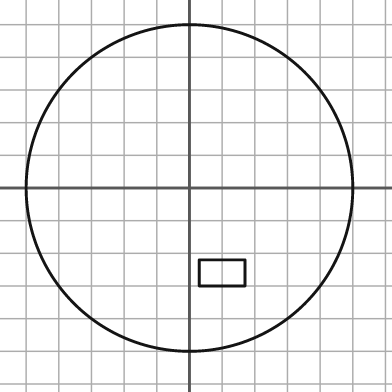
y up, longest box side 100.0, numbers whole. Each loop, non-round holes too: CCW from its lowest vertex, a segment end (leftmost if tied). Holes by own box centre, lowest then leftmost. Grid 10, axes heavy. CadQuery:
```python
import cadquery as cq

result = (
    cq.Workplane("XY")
    .moveTo(0.0, 0.0)
    .circle(50.0)
    .moveTo(3.0, -30.0)
    .lineTo(17.0, -30.0)
    .lineTo(17.0, -22.0)
    .lineTo(3.0, -22.0)
    .close()
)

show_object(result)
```